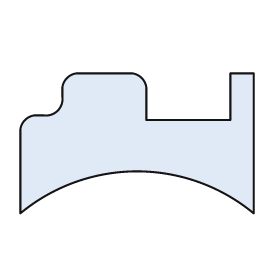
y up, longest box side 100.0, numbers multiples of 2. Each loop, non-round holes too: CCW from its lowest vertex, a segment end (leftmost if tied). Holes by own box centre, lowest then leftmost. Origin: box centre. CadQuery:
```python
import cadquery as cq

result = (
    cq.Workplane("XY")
    .moveTo(-50.0, -30.0)
    .threePointArc((0.0, -12.0), (50.0, -30.0))
    .lineTo(50.0, 30.0)
    .lineTo(40.0, 30.0)
    .lineTo(40.0, 10.0)
    .lineTo(4.0, 10.0)
    .lineTo(4.0, 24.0)
    .threePointArc((2.0, 28.0), (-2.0, 30.0))
    .lineTo(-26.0, 30.0)
    .threePointArc((-30.0, 28.0), (-32.0, 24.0))
    .lineTo(-32.0, 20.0)
    .threePointArc((-34.0, 14.0), (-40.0, 12.0))
    .lineTo(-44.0, 12.0)
    .threePointArc((-48.0, 10.0), (-50.0, 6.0))
    .close()
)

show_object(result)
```